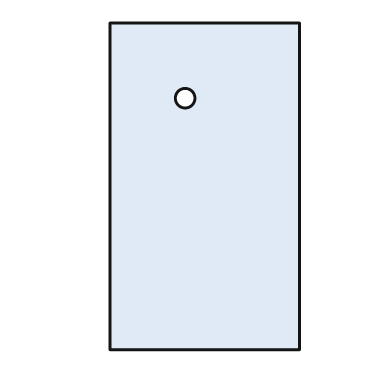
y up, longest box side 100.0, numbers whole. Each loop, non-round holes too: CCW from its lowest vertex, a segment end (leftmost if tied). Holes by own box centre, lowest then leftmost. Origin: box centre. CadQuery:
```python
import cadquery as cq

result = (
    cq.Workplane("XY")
    .moveTo(-29.0, -50.0)
    .lineTo(29.0, -50.0)
    .lineTo(29.0, 50.0)
    .lineTo(-29.0, 50.0)
    .close()
    .moveTo(-6.0, 27.0)
    .circle(3.0)
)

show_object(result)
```